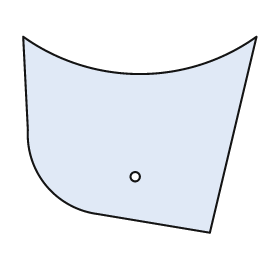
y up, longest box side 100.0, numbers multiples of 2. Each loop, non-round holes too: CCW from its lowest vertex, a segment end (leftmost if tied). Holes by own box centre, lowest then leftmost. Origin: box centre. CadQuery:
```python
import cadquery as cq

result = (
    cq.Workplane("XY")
    .moveTo(30.0, -42.0)
    .lineTo(50.0, 42.0)
    .threePointArc((0.0, 26.0), (-50.0, 42.0))
    .lineTo(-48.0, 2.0)
    .threePointArc((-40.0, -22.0), (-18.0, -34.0))
    .close()
    .moveTo(-2.0, -18.0)
    .circle(2.0)
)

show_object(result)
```